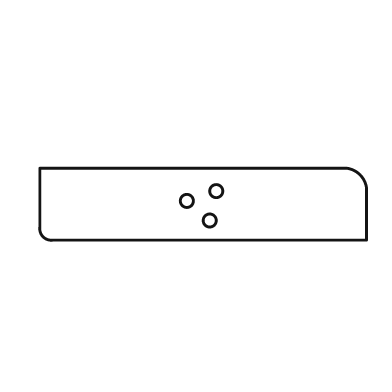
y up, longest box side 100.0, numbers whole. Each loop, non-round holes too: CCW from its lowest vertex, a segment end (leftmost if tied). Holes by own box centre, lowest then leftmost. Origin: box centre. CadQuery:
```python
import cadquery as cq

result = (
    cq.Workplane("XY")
    .moveTo(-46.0, -11.0)
    .lineTo(50.0, -11.0)
    .lineTo(50.0, 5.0)
    .threePointArc((48.0, 9.0), (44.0, 11.0))
    .lineTo(-50.0, 11.0)
    .lineTo(-50.0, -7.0)
    .threePointArc((-49.0, -10.0), (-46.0, -11.0))
    .close()
    .moveTo(2.0, -5.0)
    .circle(2.0)
    .moveTo(-5.0, 1.0)
    .circle(2.0)
    .moveTo(4.0, 4.0)
    .circle(2.0)
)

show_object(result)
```